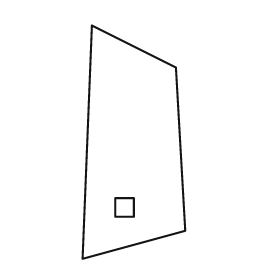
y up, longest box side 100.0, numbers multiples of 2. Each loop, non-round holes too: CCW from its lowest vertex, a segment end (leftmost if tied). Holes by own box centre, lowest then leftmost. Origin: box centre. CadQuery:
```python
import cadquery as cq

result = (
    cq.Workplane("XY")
    .moveTo(-22.0, -50.0)
    .lineTo(22.0, -38.0)
    .lineTo(18.0, 32.0)
    .lineTo(-18.0, 50.0)
    .close()
    .moveTo(-8.0, -32.0)
    .lineTo(0.0, -32.0)
    .lineTo(0.0, -24.0)
    .lineTo(-8.0, -24.0)
    .close()
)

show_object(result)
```